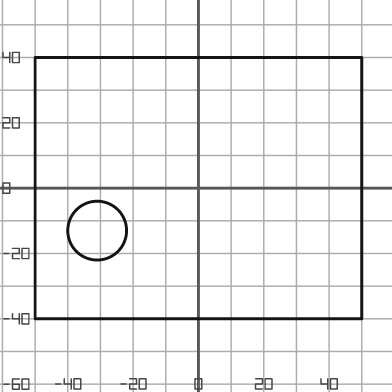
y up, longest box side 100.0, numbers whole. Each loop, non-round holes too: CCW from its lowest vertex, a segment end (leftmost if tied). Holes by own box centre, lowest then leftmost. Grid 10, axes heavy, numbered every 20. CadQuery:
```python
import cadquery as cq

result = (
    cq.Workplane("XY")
    .moveTo(-50.0, -40.0)
    .lineTo(50.0, -40.0)
    .lineTo(50.0, 40.0)
    .lineTo(-50.0, 40.0)
    .close()
    .moveTo(-31.0, -13.0)
    .circle(9.0)
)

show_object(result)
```